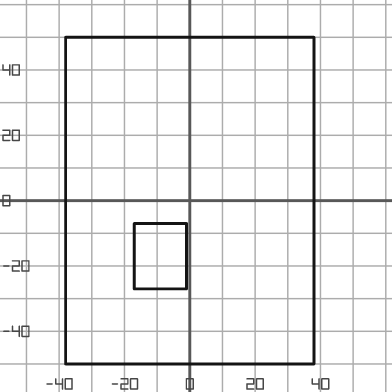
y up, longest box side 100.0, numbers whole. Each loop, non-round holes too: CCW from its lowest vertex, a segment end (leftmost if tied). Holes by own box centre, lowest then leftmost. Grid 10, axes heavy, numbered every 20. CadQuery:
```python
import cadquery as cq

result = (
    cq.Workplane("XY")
    .moveTo(-38.0, -50.0)
    .lineTo(38.0, -50.0)
    .lineTo(38.0, 50.0)
    .lineTo(-38.0, 50.0)
    .close()
    .moveTo(-17.0, -27.0)
    .lineTo(-1.0, -27.0)
    .lineTo(-1.0, -7.0)
    .lineTo(-17.0, -7.0)
    .close()
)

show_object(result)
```